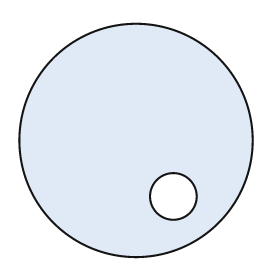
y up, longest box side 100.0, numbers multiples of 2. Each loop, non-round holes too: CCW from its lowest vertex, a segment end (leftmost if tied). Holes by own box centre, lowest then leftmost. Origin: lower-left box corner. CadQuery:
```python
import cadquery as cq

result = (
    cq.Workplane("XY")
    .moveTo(50.0, 50.0)
    .circle(50.0)
    .moveTo(66.0, 26.0)
    .circle(10.0)
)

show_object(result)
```